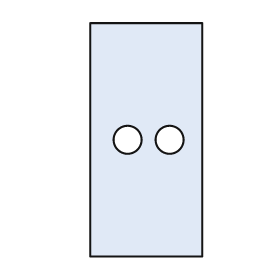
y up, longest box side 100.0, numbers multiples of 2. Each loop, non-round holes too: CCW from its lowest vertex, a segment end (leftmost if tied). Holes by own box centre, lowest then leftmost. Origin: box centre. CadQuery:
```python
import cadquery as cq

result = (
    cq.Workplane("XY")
    .moveTo(-24.0, -50.0)
    .lineTo(24.0, -50.0)
    .lineTo(24.0, 50.0)
    .lineTo(-24.0, 50.0)
    .close()
    .moveTo(-8.0, 0.0)
    .circle(6.0)
    .moveTo(10.0, 0.0)
    .circle(6.0)
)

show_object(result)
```